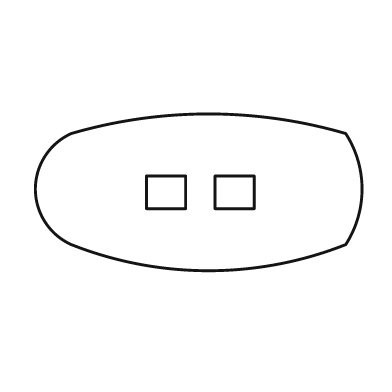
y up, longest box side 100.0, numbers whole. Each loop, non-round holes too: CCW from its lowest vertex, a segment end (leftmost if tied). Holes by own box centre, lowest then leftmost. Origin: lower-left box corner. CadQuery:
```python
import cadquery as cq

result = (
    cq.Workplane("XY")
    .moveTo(11.0, 8.0)
    .threePointArc((53.0, 0.0), (95.0, 8.0))
    .threePointArc((100.0, 25.0), (95.0, 42.0))
    .threePointArc((53.0, 48.0), (11.0, 42.0))
    .threePointArc((0.0, 25.0), (11.0, 8.0))
    .close()
    .moveTo(34.0, 19.0)
    .lineTo(46.0, 19.0)
    .lineTo(46.0, 29.0)
    .lineTo(34.0, 29.0)
    .close()
    .moveTo(55.0, 19.0)
    .lineTo(67.0, 19.0)
    .lineTo(67.0, 29.0)
    .lineTo(55.0, 29.0)
    .close()
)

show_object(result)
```